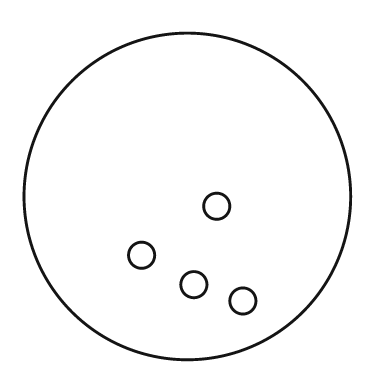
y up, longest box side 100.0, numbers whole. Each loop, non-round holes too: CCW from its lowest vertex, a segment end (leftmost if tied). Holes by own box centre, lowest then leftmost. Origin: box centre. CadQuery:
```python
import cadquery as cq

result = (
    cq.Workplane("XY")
    .moveTo(0.0, 0.0)
    .circle(50.0)
    .moveTo(17.0, -32.0)
    .circle(4.0)
    .moveTo(2.0, -27.0)
    .circle(4.0)
    .moveTo(-14.0, -18.0)
    .circle(4.0)
    .moveTo(9.0, -3.0)
    .circle(4.0)
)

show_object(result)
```